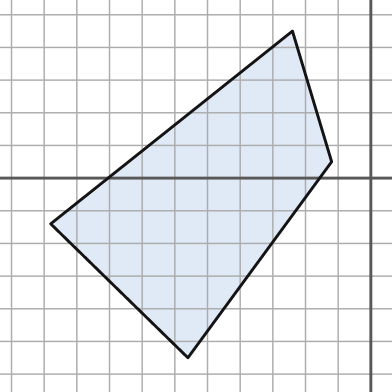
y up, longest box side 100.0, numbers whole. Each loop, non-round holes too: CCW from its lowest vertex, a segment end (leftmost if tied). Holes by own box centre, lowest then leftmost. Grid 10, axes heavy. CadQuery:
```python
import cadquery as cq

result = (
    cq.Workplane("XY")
    .moveTo(-56.0, -55.0)
    .lineTo(-12.0, 5.0)
    .lineTo(-24.0, 45.0)
    .lineTo(-98.0, -14.0)
    .close()
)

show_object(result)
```